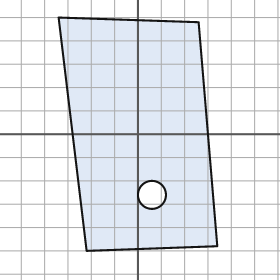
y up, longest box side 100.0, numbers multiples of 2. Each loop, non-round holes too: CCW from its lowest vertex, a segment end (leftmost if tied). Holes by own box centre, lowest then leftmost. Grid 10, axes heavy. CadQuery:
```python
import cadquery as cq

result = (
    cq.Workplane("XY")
    .moveTo(-22.0, -50.0)
    .lineTo(34.0, -48.0)
    .lineTo(26.0, 48.0)
    .lineTo(-34.0, 50.0)
    .close()
    .moveTo(6.0, -26.0)
    .circle(6.0)
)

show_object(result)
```